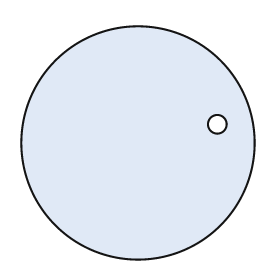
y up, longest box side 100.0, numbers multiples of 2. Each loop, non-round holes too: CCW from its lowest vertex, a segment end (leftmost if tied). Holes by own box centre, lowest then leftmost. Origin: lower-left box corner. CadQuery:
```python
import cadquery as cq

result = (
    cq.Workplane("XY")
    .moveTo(50.0, 50.0)
    .circle(50.0)
    .moveTo(84.0, 58.0)
    .circle(4.0)
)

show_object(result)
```